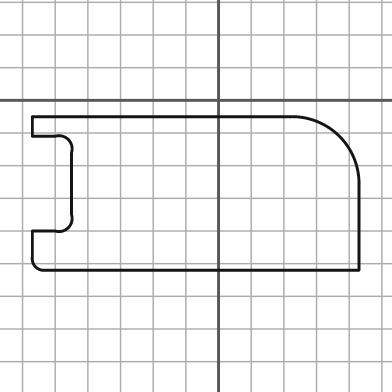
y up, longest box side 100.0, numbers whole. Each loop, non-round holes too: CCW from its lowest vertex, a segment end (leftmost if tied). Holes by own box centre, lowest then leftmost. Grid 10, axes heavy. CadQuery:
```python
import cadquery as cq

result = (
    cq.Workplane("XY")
    .moveTo(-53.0, -52.0)
    .lineTo(43.0, -52.0)
    .lineTo(43.0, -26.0)
    .threePointArc((37.0, -11.0), (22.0, -5.0))
    .lineTo(-57.0, -5.0)
    .lineTo(-57.0, -11.0)
    .lineTo(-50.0, -11.0)
    .threePointArc((-46.0, -12.0), (-45.0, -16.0))
    .lineTo(-45.0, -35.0)
    .threePointArc((-46.0, -39.0), (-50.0, -40.0))
    .lineTo(-57.0, -40.0)
    .lineTo(-57.0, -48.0)
    .threePointArc((-56.0, -51.0), (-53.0, -52.0))
    .close()
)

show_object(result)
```